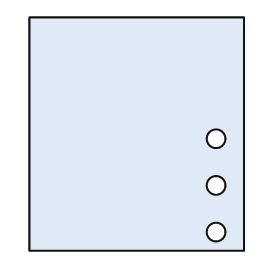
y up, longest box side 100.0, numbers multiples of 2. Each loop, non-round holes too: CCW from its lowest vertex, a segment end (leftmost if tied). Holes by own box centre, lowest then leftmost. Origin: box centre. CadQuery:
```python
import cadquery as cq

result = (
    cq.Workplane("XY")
    .moveTo(-46.0, -50.0)
    .lineTo(46.0, -50.0)
    .lineTo(46.0, 50.0)
    .lineTo(-46.0, 50.0)
    .close()
    .moveTo(34.0, -42.0)
    .circle(4.0)
    .moveTo(34.0, -22.0)
    .circle(4.0)
    .moveTo(34.0, -2.0)
    .circle(4.0)
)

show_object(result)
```